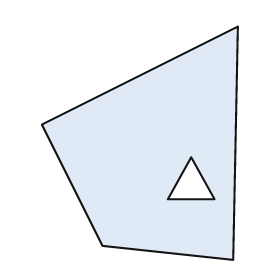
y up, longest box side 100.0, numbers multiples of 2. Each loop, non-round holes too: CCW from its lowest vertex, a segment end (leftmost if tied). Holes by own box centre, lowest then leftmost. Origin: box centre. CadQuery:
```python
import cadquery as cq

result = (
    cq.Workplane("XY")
    .moveTo(40.0, -50.0)
    .lineTo(42.0, 50.0)
    .lineTo(-42.0, 8.0)
    .lineTo(-16.0, -44.0)
    .close()
    .moveTo(12.0, -24.0)
    .lineTo(32.0, -24.0)
    .lineTo(22.0, -6.0)
    .close()
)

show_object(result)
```